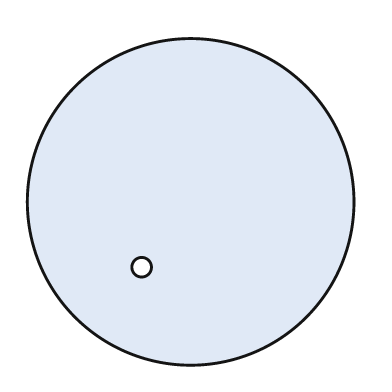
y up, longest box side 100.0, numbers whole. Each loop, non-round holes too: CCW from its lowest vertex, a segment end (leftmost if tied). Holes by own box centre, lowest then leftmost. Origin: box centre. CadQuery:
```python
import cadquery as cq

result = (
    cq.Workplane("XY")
    .moveTo(0.0, 0.0)
    .circle(50.0)
    .moveTo(-15.0, -20.0)
    .circle(3.0)
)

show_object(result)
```